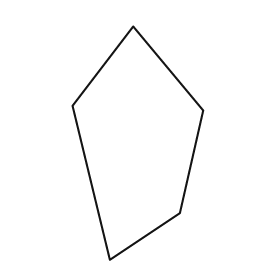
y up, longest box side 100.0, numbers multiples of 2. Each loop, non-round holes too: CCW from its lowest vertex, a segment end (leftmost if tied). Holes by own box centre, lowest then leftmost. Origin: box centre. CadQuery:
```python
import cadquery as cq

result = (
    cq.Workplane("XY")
    .moveTo(-12.0, -50.0)
    .lineTo(18.0, -30.0)
    .lineTo(28.0, 14.0)
    .lineTo(-2.0, 50.0)
    .lineTo(-28.0, 16.0)
    .close()
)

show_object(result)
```